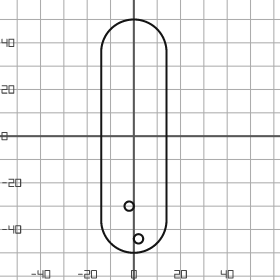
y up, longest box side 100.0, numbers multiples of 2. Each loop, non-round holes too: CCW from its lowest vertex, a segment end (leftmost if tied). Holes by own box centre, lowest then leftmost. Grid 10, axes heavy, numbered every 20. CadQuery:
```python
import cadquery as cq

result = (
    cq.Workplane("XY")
    .moveTo(-14.0, -36.0)
    .threePointArc((0.0, -50.0), (14.0, -36.0))
    .lineTo(14.0, 36.0)
    .threePointArc((0.0, 50.0), (-14.0, 36.0))
    .close()
    .moveTo(2.0, -44.0)
    .circle(2.0)
    .moveTo(-2.0, -30.0)
    .circle(2.0)
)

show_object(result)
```